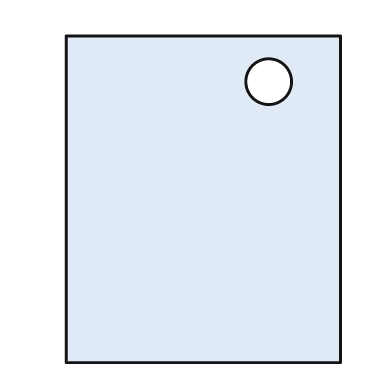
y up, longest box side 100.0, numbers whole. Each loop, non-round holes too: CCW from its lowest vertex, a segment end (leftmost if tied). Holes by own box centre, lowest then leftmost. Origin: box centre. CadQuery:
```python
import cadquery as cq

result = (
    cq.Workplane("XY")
    .moveTo(-42.0, -50.0)
    .lineTo(42.0, -50.0)
    .lineTo(42.0, 50.0)
    .lineTo(-42.0, 50.0)
    .close()
    .moveTo(20.0, 36.0)
    .circle(7.0)
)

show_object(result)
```